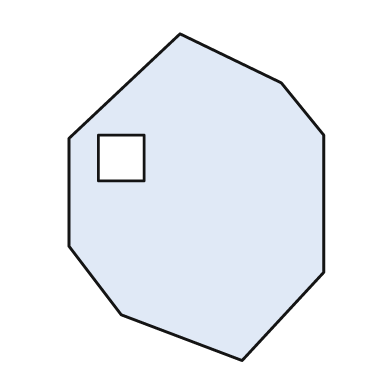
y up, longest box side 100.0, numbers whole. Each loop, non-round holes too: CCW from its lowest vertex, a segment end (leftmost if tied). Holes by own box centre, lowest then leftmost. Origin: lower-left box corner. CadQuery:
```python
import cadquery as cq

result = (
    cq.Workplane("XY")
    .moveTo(53.0, 0.0)
    .lineTo(78.0, 27.0)
    .lineTo(78.0, 69.0)
    .lineTo(65.0, 85.0)
    .lineTo(34.0, 100.0)
    .lineTo(0.0, 68.0)
    .lineTo(0.0, 35.0)
    .lineTo(16.0, 14.0)
    .close()
    .moveTo(9.0, 55.0)
    .lineTo(23.0, 55.0)
    .lineTo(23.0, 69.0)
    .lineTo(9.0, 69.0)
    .close()
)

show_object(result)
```